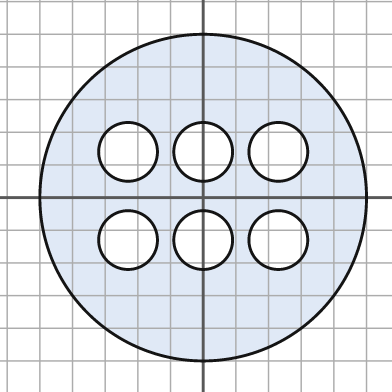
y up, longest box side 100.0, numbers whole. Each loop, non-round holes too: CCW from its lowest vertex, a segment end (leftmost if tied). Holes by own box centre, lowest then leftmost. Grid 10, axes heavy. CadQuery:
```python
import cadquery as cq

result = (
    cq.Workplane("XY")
    .moveTo(0.0, 0.0)
    .circle(50.0)
    .moveTo(-23.0, -13.0)
    .circle(9.0)
    .moveTo(0.0, -13.0)
    .circle(9.0)
    .moveTo(23.0, -13.0)
    .circle(9.0)
    .moveTo(-23.0, 14.0)
    .circle(9.0)
    .moveTo(0.0, 14.0)
    .circle(9.0)
    .moveTo(23.0, 14.0)
    .circle(9.0)
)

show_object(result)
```